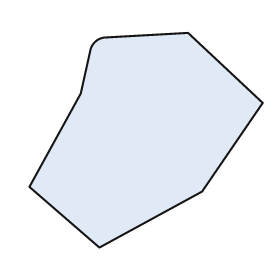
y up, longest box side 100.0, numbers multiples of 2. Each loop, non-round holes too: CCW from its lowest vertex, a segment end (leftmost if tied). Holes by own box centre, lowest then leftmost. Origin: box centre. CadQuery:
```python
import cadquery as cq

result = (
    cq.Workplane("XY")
    .moveTo(-20.0, -46.0)
    .lineTo(24.0, -22.0)
    .lineTo(50.0, 16.0)
    .lineTo(18.0, 46.0)
    .lineTo(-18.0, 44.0)
    .threePointArc((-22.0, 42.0), (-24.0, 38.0))
    .lineTo(-28.0, 20.0)
    .lineTo(-50.0, -20.0)
    .close()
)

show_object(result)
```